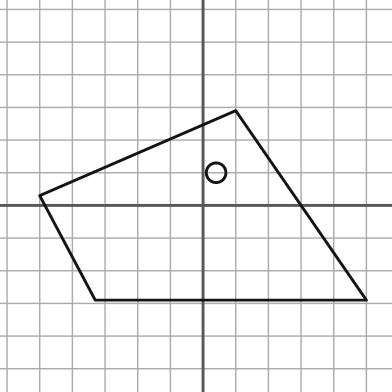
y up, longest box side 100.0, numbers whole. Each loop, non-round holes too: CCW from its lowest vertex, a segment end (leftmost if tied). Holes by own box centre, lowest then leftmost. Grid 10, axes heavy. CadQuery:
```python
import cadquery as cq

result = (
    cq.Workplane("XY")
    .moveTo(-33.0, -29.0)
    .lineTo(50.0, -29.0)
    .lineTo(10.0, 29.0)
    .lineTo(-50.0, 3.0)
    .close()
    .moveTo(4.0, 10.0)
    .circle(3.0)
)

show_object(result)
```